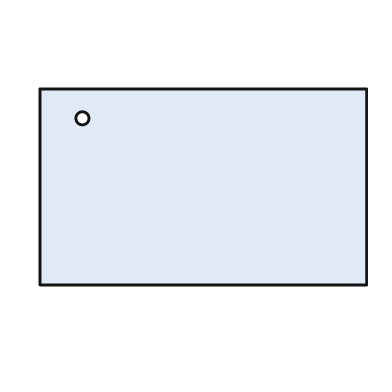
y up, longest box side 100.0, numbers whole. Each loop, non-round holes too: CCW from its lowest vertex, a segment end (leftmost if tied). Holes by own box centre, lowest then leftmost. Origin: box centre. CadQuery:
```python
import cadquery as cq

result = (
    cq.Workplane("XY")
    .moveTo(-50.0, -30.0)
    .lineTo(50.0, -30.0)
    .lineTo(50.0, 30.0)
    .lineTo(-50.0, 30.0)
    .close()
    .moveTo(-37.0, 21.0)
    .circle(2.0)
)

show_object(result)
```